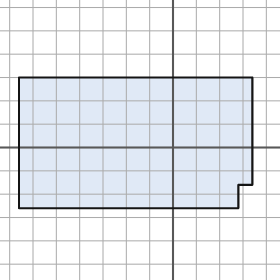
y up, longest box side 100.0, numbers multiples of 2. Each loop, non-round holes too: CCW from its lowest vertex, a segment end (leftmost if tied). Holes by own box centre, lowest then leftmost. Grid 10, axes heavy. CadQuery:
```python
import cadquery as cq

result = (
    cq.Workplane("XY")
    .moveTo(-66.0, -26.0)
    .lineTo(28.0, -26.0)
    .lineTo(28.0, -16.0)
    .lineTo(34.0, -16.0)
    .lineTo(34.0, 30.0)
    .lineTo(-66.0, 30.0)
    .close()
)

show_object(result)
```